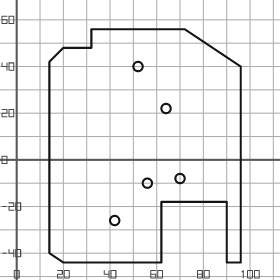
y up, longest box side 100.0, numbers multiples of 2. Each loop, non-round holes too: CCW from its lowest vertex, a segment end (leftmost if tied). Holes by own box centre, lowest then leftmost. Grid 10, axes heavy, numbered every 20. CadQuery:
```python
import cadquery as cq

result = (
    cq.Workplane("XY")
    .moveTo(20.0, -44.0)
    .lineTo(62.0, -44.0)
    .lineTo(62.0, -18.0)
    .lineTo(90.0, -18.0)
    .lineTo(90.0, -44.0)
    .lineTo(96.0, -44.0)
    .lineTo(96.0, 40.0)
    .lineTo(72.0, 56.0)
    .lineTo(32.0, 56.0)
    .lineTo(32.0, 48.0)
    .lineTo(20.0, 48.0)
    .lineTo(14.0, 42.0)
    .lineTo(14.0, -40.0)
    .close()
    .moveTo(42.0, -26.0)
    .circle(2.0)
    .moveTo(56.0, -10.0)
    .circle(2.0)
    .moveTo(70.0, -8.0)
    .circle(2.0)
    .moveTo(64.0, 22.0)
    .circle(2.0)
    .moveTo(52.0, 40.0)
    .circle(2.0)
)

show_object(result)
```